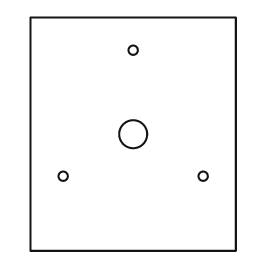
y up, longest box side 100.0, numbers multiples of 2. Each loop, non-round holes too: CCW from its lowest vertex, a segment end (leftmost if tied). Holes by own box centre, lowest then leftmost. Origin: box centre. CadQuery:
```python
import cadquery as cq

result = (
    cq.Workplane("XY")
    .moveTo(-44.0, -50.0)
    .lineTo(44.0, -50.0)
    .lineTo(44.0, 50.0)
    .lineTo(-44.0, 50.0)
    .close()
    .moveTo(-30.0, -18.0)
    .circle(2.0)
    .moveTo(30.0, -18.0)
    .circle(2.0)
    .moveTo(0.0, 0.0)
    .circle(6.0)
    .moveTo(0.0, 36.0)
    .circle(2.0)
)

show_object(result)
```